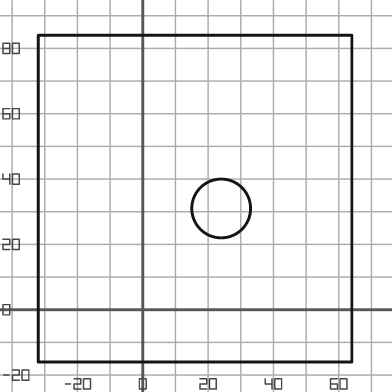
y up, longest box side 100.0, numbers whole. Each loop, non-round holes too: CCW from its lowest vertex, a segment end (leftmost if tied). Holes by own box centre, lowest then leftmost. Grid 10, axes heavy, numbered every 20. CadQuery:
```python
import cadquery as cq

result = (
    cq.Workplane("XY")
    .moveTo(-32.0, -16.0)
    .lineTo(64.0, -16.0)
    .lineTo(64.0, 84.0)
    .lineTo(-32.0, 84.0)
    .close()
    .moveTo(24.0, 31.0)
    .circle(9.0)
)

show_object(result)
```